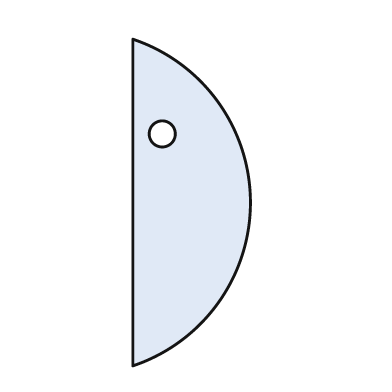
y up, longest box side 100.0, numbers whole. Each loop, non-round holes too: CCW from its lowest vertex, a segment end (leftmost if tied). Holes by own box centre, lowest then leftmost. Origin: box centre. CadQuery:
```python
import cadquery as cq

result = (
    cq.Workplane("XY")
    .moveTo(-18.0, -50.0)
    .threePointArc((18.0, 0.0), (-18.0, 50.0))
    .close()
    .moveTo(-9.0, 21.0)
    .circle(4.0)
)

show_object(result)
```